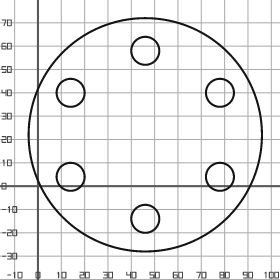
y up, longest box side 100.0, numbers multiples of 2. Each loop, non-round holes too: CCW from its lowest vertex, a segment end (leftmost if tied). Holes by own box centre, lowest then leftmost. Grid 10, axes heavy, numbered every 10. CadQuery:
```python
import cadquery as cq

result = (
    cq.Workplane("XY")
    .moveTo(46.0, 22.0)
    .circle(50.0)
    .moveTo(46.0, -14.0)
    .circle(6.0)
    .moveTo(14.0, 4.0)
    .circle(6.0)
    .moveTo(78.0, 4.0)
    .circle(6.0)
    .moveTo(14.0, 40.0)
    .circle(6.0)
    .moveTo(78.0, 40.0)
    .circle(6.0)
    .moveTo(46.0, 58.0)
    .circle(6.0)
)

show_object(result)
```